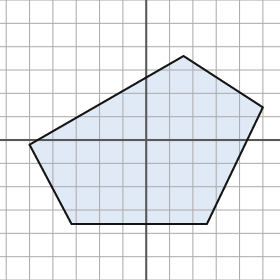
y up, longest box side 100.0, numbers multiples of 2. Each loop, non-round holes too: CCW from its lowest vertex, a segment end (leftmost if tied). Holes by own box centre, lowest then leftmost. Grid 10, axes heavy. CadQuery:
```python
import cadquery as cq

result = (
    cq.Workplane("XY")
    .moveTo(-32.0, -36.0)
    .lineTo(26.0, -36.0)
    .lineTo(50.0, 14.0)
    .lineTo(16.0, 36.0)
    .lineTo(-50.0, -2.0)
    .close()
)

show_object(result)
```